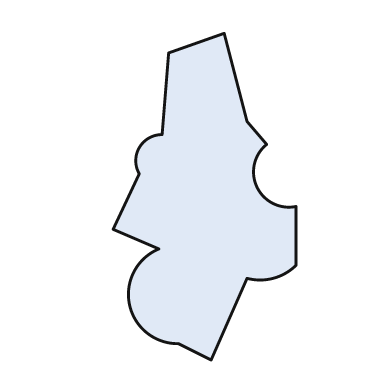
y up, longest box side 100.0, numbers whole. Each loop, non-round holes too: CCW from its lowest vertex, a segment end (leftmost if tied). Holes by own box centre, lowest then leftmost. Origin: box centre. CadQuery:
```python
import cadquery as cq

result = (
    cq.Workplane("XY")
    .moveTo(2.0, -50.0)
    .lineTo(13.0, -25.0)
    .threePointArc((21.0, -25.0), (28.0, -21.0))
    .lineTo(28.0, -3.0)
    .threePointArc((16.0, 3.0), (19.0, 16.0))
    .lineTo(13.0, 23.0)
    .lineTo(6.0, 50.0)
    .lineTo(-11.0, 44.0)
    .lineTo(-13.0, 19.0)
    .threePointArc((-20.0, 15.0), (-20.0, 7.0))
    .lineTo(-28.0, -10.0)
    .lineTo(-14.0, -16.0)
    .threePointArc((-23.0, -33.0), (-8.0, -45.0))
    .close()
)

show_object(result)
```